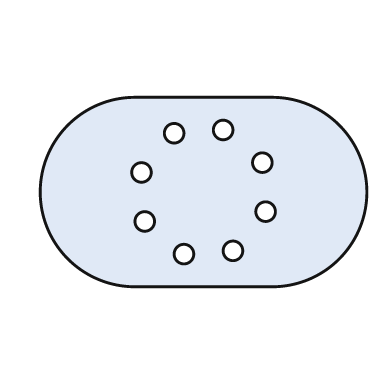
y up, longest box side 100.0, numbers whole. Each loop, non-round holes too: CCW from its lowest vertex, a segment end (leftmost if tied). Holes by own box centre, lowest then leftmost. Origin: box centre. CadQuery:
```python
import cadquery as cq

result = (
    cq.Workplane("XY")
    .moveTo(-21.0, -29.0)
    .lineTo(21.0, -29.0)
    .threePointArc((50.0, 0.0), (21.0, 29.0))
    .lineTo(-21.0, 29.0)
    .threePointArc((-50.0, 0.0), (-21.0, -29.0))
    .close()
    .moveTo(-6.0, -19.0)
    .circle(3.0)
    .moveTo(9.0, -18.0)
    .circle(3.0)
    .moveTo(-18.0, -9.0)
    .circle(3.0)
    .moveTo(19.0, -6.0)
    .circle(3.0)
    .moveTo(-19.0, 6.0)
    .circle(3.0)
    .moveTo(18.0, 9.0)
    .circle(3.0)
    .moveTo(-9.0, 18.0)
    .circle(3.0)
    .moveTo(6.0, 19.0)
    .circle(3.0)
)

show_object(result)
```